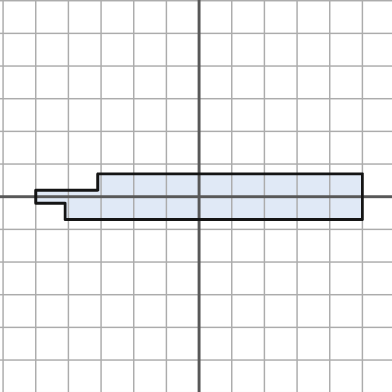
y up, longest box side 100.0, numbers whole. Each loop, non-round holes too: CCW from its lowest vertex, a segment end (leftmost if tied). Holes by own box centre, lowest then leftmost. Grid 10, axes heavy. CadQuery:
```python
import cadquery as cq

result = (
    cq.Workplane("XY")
    .moveTo(-41.0, -7.0)
    .lineTo(50.0, -7.0)
    .lineTo(50.0, 7.0)
    .lineTo(-31.0, 7.0)
    .lineTo(-31.0, 2.0)
    .lineTo(-50.0, 2.0)
    .lineTo(-50.0, -2.0)
    .lineTo(-41.0, -2.0)
    .close()
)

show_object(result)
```